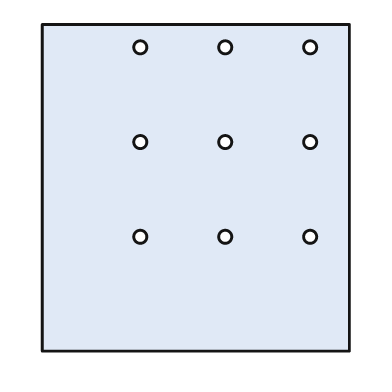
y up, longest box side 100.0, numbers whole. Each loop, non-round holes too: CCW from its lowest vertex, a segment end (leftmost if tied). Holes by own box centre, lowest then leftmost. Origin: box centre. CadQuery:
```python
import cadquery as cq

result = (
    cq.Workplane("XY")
    .moveTo(-47.0, -50.0)
    .lineTo(47.0, -50.0)
    .lineTo(47.0, 50.0)
    .lineTo(-47.0, 50.0)
    .close()
    .moveTo(-17.0, -15.0)
    .circle(2.0)
    .moveTo(9.0, -15.0)
    .circle(2.0)
    .moveTo(35.0, -15.0)
    .circle(2.0)
    .moveTo(-17.0, 14.0)
    .circle(2.0)
    .moveTo(9.0, 14.0)
    .circle(2.0)
    .moveTo(35.0, 14.0)
    .circle(2.0)
    .moveTo(-17.0, 43.0)
    .circle(2.0)
    .moveTo(9.0, 43.0)
    .circle(2.0)
    .moveTo(35.0, 43.0)
    .circle(2.0)
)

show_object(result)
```